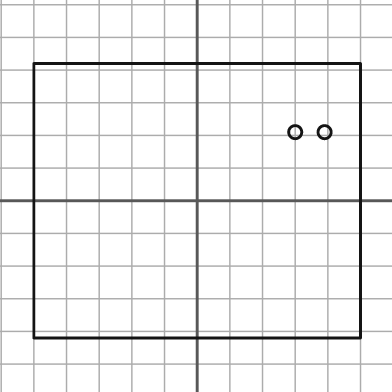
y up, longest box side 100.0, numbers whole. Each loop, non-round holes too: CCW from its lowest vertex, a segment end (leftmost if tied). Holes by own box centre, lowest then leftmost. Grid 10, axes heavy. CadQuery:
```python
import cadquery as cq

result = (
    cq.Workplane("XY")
    .moveTo(-50.0, -42.0)
    .lineTo(50.0, -42.0)
    .lineTo(50.0, 42.0)
    .lineTo(-50.0, 42.0)
    .close()
    .moveTo(30.0, 21.0)
    .circle(2.0)
    .moveTo(39.0, 21.0)
    .circle(2.0)
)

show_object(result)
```